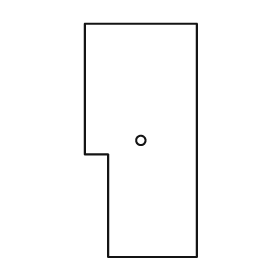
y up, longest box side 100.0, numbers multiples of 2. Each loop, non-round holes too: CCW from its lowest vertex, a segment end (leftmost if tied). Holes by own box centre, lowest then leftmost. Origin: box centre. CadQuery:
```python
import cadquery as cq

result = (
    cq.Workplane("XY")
    .moveTo(-14.0, -50.0)
    .lineTo(24.0, -50.0)
    .lineTo(24.0, 50.0)
    .lineTo(-24.0, 50.0)
    .lineTo(-24.0, -6.0)
    .lineTo(-14.0, -6.0)
    .close()
    .moveTo(0.0, 0.0)
    .circle(2.0)
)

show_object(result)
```